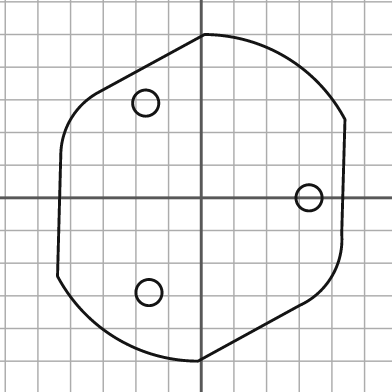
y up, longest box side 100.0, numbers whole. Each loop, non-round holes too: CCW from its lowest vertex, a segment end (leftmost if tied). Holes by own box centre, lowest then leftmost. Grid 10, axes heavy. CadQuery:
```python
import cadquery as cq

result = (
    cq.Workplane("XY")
    .moveTo(-1.0, -50.0)
    .lineTo(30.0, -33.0)
    .threePointArc((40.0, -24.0), (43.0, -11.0))
    .lineTo(44.0, 24.0)
    .threePointArc((26.0, 43.0), (1.0, 50.0))
    .lineTo(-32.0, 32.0)
    .threePointArc((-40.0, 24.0), (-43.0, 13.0))
    .lineTo(-44.0, -24.0)
    .threePointArc((-26.0, -43.0), (-1.0, -50.0))
    .close()
    .moveTo(-16.0, -29.0)
    .circle(4.0)
    .moveTo(33.0, 0.0)
    .circle(4.0)
    .moveTo(-17.0, 29.0)
    .circle(4.0)
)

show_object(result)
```